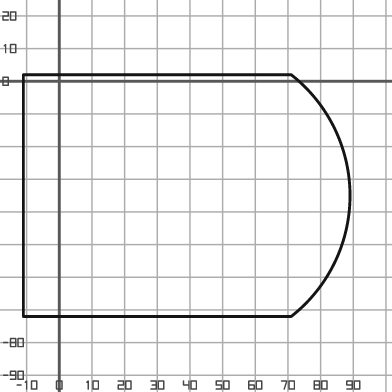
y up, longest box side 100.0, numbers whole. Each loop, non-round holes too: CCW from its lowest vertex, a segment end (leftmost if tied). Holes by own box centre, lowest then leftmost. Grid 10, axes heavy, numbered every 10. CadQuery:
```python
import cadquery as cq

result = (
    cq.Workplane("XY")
    .moveTo(-11.0, -72.0)
    .lineTo(71.0, -72.0)
    .threePointArc((89.0, -35.0), (71.0, 2.0))
    .lineTo(-11.0, 2.0)
    .close()
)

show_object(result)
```